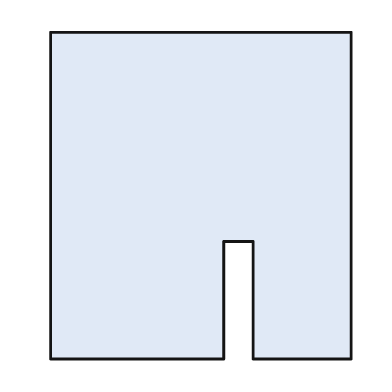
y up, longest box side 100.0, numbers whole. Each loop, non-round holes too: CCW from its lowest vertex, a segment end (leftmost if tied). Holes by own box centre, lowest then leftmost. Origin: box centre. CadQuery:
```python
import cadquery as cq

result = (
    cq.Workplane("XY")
    .moveTo(-46.0, -50.0)
    .lineTo(7.0, -50.0)
    .lineTo(7.0, -14.0)
    .lineTo(16.0, -14.0)
    .lineTo(16.0, -50.0)
    .lineTo(46.0, -50.0)
    .lineTo(46.0, 50.0)
    .lineTo(-46.0, 50.0)
    .close()
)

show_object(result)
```